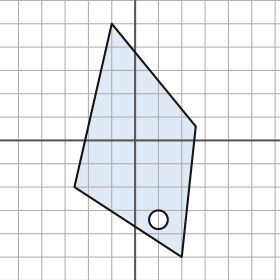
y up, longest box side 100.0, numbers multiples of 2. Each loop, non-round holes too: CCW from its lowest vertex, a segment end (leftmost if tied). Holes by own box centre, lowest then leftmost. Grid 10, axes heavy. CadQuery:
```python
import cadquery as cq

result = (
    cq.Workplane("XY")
    .moveTo(20.0, -50.0)
    .lineTo(26.0, 6.0)
    .lineTo(-10.0, 50.0)
    .lineTo(-26.0, -20.0)
    .close()
    .moveTo(10.0, -34.0)
    .circle(4.0)
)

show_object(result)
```